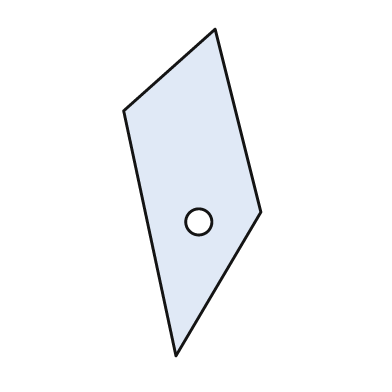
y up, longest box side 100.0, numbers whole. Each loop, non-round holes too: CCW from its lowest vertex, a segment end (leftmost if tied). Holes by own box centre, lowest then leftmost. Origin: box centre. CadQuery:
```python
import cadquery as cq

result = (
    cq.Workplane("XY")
    .moveTo(-5.0, -50.0)
    .lineTo(21.0, -6.0)
    .lineTo(7.0, 50.0)
    .lineTo(-21.0, 25.0)
    .close()
    .moveTo(2.0, -9.0)
    .circle(4.0)
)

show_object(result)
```